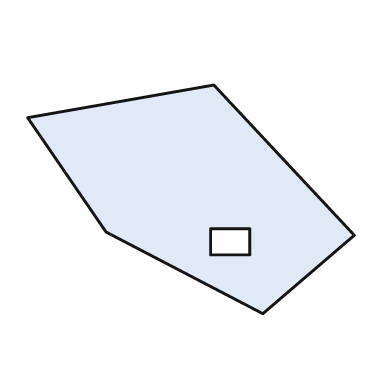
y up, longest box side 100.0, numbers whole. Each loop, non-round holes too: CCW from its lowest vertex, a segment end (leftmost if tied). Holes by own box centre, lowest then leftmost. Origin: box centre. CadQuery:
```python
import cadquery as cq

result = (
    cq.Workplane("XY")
    .moveTo(22.0, -35.0)
    .lineTo(50.0, -11.0)
    .lineTo(7.0, 35.0)
    .lineTo(-50.0, 25.0)
    .lineTo(-26.0, -10.0)
    .close()
    .moveTo(6.0, -17.0)
    .lineTo(18.0, -17.0)
    .lineTo(18.0, -9.0)
    .lineTo(6.0, -9.0)
    .close()
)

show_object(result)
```